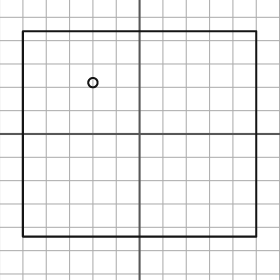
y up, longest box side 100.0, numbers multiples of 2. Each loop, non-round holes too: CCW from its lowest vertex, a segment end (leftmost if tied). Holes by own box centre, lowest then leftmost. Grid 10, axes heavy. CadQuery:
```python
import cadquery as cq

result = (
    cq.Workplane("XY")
    .moveTo(-50.0, -44.0)
    .lineTo(50.0, -44.0)
    .lineTo(50.0, 44.0)
    .lineTo(-50.0, 44.0)
    .close()
    .moveTo(-20.0, 22.0)
    .circle(2.0)
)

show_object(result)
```